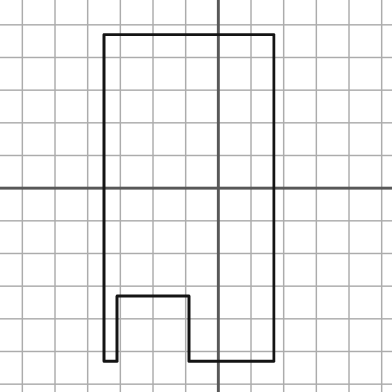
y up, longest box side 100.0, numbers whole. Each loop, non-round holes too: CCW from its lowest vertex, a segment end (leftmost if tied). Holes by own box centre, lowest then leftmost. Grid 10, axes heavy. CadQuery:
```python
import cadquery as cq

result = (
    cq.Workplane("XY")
    .moveTo(-35.0, -53.0)
    .lineTo(-31.0, -53.0)
    .lineTo(-31.0, -33.0)
    .lineTo(-9.0, -33.0)
    .lineTo(-9.0, -53.0)
    .lineTo(17.0, -53.0)
    .lineTo(17.0, 47.0)
    .lineTo(-35.0, 47.0)
    .close()
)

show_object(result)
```